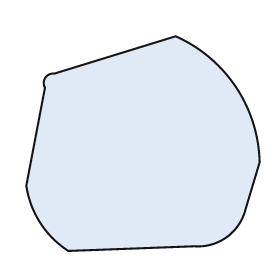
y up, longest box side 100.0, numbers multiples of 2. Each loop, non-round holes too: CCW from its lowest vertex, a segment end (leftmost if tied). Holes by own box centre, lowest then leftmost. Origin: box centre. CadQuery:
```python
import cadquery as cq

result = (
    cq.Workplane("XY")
    .moveTo(-32.0, -46.0)
    .lineTo(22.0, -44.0)
    .threePointArc((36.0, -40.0), (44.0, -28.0))
    .lineTo(50.0, -8.0)
    .threePointArc((40.0, 24.0), (14.0, 46.0))
    .lineTo(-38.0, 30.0)
    .threePointArc((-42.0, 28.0), (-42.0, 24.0))
    .lineTo(-50.0, -18.0)
    .threePointArc((-44.0, -34.0), (-32.0, -46.0))
    .close()
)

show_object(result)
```